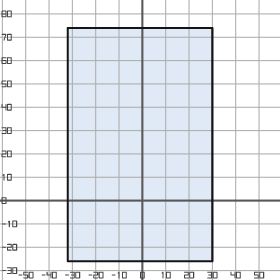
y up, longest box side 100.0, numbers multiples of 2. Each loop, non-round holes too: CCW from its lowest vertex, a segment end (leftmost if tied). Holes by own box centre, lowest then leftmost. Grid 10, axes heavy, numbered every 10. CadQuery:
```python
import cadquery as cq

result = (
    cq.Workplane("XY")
    .moveTo(-32.0, -26.0)
    .lineTo(30.0, -26.0)
    .lineTo(30.0, 74.0)
    .lineTo(-32.0, 74.0)
    .close()
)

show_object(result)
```